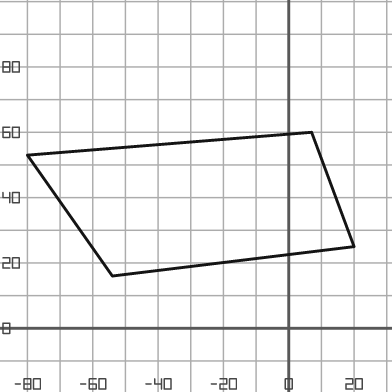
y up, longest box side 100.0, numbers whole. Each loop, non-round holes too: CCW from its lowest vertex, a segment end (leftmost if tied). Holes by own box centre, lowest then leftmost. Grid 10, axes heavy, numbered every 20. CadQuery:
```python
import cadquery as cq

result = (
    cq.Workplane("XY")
    .moveTo(-54.0, 16.0)
    .lineTo(20.0, 25.0)
    .lineTo(7.0, 60.0)
    .lineTo(-80.0, 53.0)
    .close()
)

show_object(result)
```